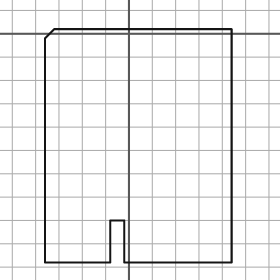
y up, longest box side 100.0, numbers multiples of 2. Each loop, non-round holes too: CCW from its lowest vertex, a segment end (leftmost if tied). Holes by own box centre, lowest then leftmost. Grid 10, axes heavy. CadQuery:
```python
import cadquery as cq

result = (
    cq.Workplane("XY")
    .moveTo(-36.0, -98.0)
    .lineTo(-8.0, -98.0)
    .lineTo(-8.0, -80.0)
    .lineTo(-2.0, -80.0)
    .lineTo(-2.0, -98.0)
    .lineTo(44.0, -98.0)
    .lineTo(44.0, 2.0)
    .lineTo(-32.0, 2.0)
    .lineTo(-36.0, -2.0)
    .close()
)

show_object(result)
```